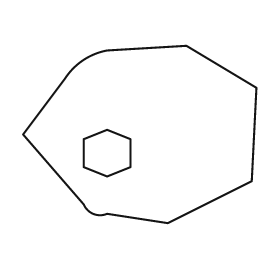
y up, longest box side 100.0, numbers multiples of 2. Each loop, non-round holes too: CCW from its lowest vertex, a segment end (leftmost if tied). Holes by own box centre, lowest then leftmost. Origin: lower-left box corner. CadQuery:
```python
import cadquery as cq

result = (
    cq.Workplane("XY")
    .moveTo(62.0, 0.0)
    .lineTo(98.0, 18.0)
    .lineTo(100.0, 58.0)
    .lineTo(70.0, 76.0)
    .lineTo(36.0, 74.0)
    .threePointArc((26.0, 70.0), (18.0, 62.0))
    .lineTo(0.0, 38.0)
    .lineTo(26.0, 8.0)
    .threePointArc((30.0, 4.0), (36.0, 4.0))
    .close()
    .moveTo(36.0, 20.0)
    .lineTo(46.0, 24.0)
    .lineTo(46.0, 36.0)
    .lineTo(36.0, 40.0)
    .lineTo(26.0, 36.0)
    .lineTo(26.0, 24.0)
    .close()
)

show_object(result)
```